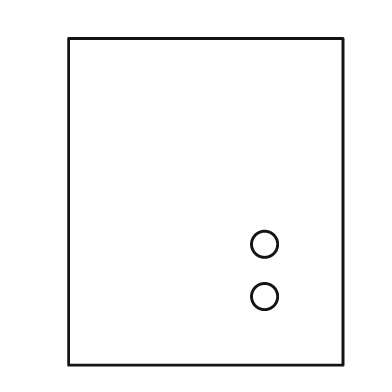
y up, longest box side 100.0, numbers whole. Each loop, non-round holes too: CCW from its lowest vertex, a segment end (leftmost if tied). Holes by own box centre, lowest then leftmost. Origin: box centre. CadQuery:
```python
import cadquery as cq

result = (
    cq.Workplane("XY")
    .moveTo(-42.0, -50.0)
    .lineTo(42.0, -50.0)
    .lineTo(42.0, 50.0)
    .lineTo(-42.0, 50.0)
    .close()
    .moveTo(18.0, -29.0)
    .circle(4.0)
    .moveTo(18.0, -13.0)
    .circle(4.0)
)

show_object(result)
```